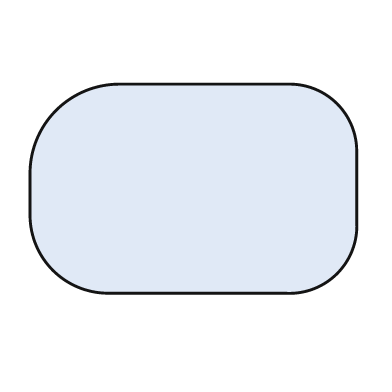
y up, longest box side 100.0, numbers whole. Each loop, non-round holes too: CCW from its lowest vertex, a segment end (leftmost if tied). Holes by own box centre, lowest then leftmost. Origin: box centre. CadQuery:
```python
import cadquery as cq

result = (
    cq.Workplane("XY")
    .moveTo(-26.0, -32.0)
    .lineTo(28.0, -32.0)
    .threePointArc((44.0, -26.0), (50.0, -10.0))
    .lineTo(50.0, 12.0)
    .threePointArc((44.0, 26.0), (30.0, 32.0))
    .lineTo(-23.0, 32.0)
    .threePointArc((-42.0, 24.0), (-50.0, 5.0))
    .lineTo(-50.0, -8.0)
    .threePointArc((-43.0, -25.0), (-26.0, -32.0))
    .close()
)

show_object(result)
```